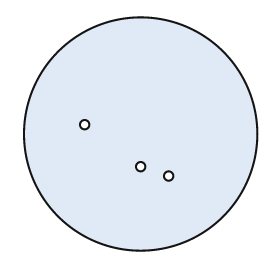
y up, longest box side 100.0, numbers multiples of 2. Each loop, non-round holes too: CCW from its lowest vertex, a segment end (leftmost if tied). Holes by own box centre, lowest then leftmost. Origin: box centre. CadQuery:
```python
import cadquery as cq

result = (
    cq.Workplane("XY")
    .moveTo(0.0, 0.0)
    .circle(50.0)
    .moveTo(12.0, -18.0)
    .circle(2.0)
    .moveTo(0.0, -14.0)
    .circle(2.0)
    .moveTo(-24.0, 4.0)
    .circle(2.0)
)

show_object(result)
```